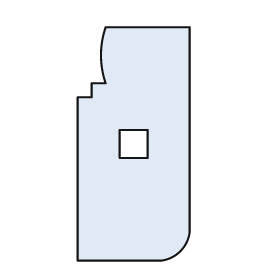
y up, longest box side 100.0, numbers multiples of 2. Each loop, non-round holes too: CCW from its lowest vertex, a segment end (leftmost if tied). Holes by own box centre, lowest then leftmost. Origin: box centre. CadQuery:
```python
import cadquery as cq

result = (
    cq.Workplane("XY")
    .moveTo(-24.0, -50.0)
    .lineTo(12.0, -50.0)
    .threePointArc((20.0, -46.0), (24.0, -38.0))
    .lineTo(24.0, 50.0)
    .lineTo(-12.0, 50.0)
    .threePointArc((-14.0, 38.0), (-12.0, 26.0))
    .lineTo(-18.0, 26.0)
    .lineTo(-18.0, 20.0)
    .lineTo(-24.0, 20.0)
    .close()
    .moveTo(-6.0, -6.0)
    .lineTo(6.0, -6.0)
    .lineTo(6.0, 6.0)
    .lineTo(-6.0, 6.0)
    .close()
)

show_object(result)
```